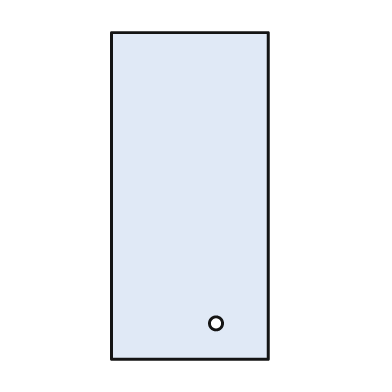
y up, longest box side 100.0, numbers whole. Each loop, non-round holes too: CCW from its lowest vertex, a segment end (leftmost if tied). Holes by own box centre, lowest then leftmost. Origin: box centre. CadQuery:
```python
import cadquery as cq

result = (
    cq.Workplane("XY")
    .moveTo(-24.0, -50.0)
    .lineTo(24.0, -50.0)
    .lineTo(24.0, 50.0)
    .lineTo(-24.0, 50.0)
    .close()
    .moveTo(8.0, -39.0)
    .circle(2.0)
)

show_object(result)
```